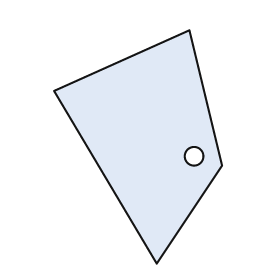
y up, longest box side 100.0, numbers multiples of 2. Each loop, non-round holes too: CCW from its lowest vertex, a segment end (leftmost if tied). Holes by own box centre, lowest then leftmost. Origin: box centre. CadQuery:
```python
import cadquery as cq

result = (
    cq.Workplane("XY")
    .moveTo(8.0, -50.0)
    .lineTo(36.0, -8.0)
    .lineTo(22.0, 50.0)
    .lineTo(-36.0, 24.0)
    .close()
    .moveTo(24.0, -4.0)
    .circle(4.0)
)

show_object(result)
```